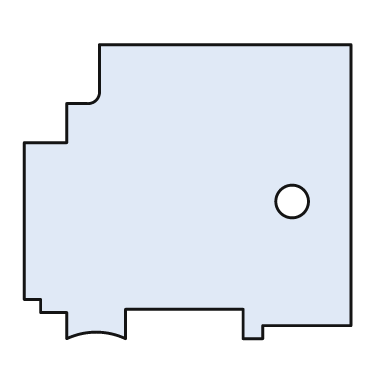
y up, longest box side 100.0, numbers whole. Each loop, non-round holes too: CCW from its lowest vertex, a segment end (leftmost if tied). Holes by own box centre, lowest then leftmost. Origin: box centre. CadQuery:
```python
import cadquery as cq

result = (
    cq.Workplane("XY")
    .moveTo(-37.0, -45.0)
    .threePointArc((-28.0, -43.0), (-19.0, -45.0))
    .lineTo(-19.0, -36.0)
    .lineTo(17.0, -36.0)
    .lineTo(17.0, -45.0)
    .lineTo(23.0, -45.0)
    .lineTo(23.0, -41.0)
    .lineTo(50.0, -41.0)
    .lineTo(50.0, 45.0)
    .lineTo(-27.0, 45.0)
    .lineTo(-27.0, 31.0)
    .threePointArc((-28.0, 28.0), (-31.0, 27.0))
    .lineTo(-37.0, 27.0)
    .lineTo(-37.0, 15.0)
    .lineTo(-50.0, 15.0)
    .lineTo(-50.0, -33.0)
    .lineTo(-45.0, -33.0)
    .lineTo(-45.0, -37.0)
    .lineTo(-37.0, -37.0)
    .close()
    .moveTo(32.0, -3.0)
    .circle(5.0)
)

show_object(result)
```